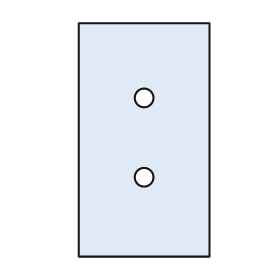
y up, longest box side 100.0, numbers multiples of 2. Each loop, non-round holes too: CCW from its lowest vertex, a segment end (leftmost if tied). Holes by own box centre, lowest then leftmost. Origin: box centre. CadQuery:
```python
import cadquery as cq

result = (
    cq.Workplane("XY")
    .moveTo(-28.0, -50.0)
    .lineTo(28.0, -50.0)
    .lineTo(28.0, 50.0)
    .lineTo(-28.0, 50.0)
    .close()
    .moveTo(0.0, -16.0)
    .circle(4.0)
    .moveTo(0.0, 18.0)
    .circle(4.0)
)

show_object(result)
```